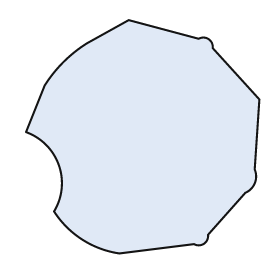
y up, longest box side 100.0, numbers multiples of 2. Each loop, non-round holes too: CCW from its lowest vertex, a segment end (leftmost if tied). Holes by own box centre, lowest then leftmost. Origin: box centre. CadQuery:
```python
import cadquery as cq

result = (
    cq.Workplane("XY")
    .moveTo(-10.0, -50.0)
    .lineTo(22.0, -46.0)
    .threePointArc((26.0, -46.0), (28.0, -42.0))
    .lineTo(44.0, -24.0)
    .threePointArc((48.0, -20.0), (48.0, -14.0))
    .lineTo(50.0, 16.0)
    .lineTo(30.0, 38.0)
    .threePointArc((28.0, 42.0), (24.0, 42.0))
    .lineTo(-6.0, 50.0)
    .lineTo(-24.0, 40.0)
    .threePointArc((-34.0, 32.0), (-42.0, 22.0))
    .lineTo(-50.0, 2.0)
    .threePointArc((-36.0, -12.0), (-38.0, -32.0))
    .threePointArc((-26.0, -44.0), (-10.0, -50.0))
    .close()
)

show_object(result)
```